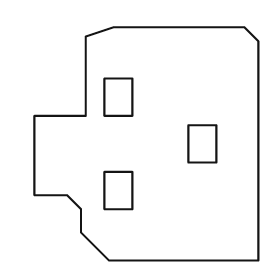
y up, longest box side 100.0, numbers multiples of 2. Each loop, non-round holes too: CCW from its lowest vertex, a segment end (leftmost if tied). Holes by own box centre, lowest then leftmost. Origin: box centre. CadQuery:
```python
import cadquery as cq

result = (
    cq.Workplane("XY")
    .moveTo(-16.0, -50.0)
    .lineTo(48.0, -50.0)
    .lineTo(48.0, 44.0)
    .lineTo(42.0, 50.0)
    .lineTo(-14.0, 50.0)
    .lineTo(-26.0, 46.0)
    .lineTo(-26.0, 12.0)
    .lineTo(-48.0, 12.0)
    .lineTo(-48.0, -22.0)
    .lineTo(-34.0, -22.0)
    .lineTo(-28.0, -28.0)
    .lineTo(-28.0, -38.0)
    .close()
    .moveTo(-18.0, -28.0)
    .lineTo(-6.0, -28.0)
    .lineTo(-6.0, -12.0)
    .lineTo(-18.0, -12.0)
    .close()
    .moveTo(18.0, -8.0)
    .lineTo(30.0, -8.0)
    .lineTo(30.0, 8.0)
    .lineTo(18.0, 8.0)
    .close()
    .moveTo(-18.0, 12.0)
    .lineTo(-6.0, 12.0)
    .lineTo(-6.0, 28.0)
    .lineTo(-18.0, 28.0)
    .close()
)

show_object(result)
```